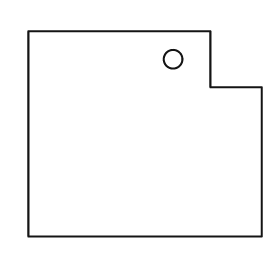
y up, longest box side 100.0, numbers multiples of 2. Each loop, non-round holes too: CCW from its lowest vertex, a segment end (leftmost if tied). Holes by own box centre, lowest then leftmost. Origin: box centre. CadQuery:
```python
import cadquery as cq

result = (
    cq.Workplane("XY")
    .moveTo(-50.0, -44.0)
    .lineTo(50.0, -44.0)
    .lineTo(50.0, 20.0)
    .lineTo(28.0, 20.0)
    .lineTo(28.0, 44.0)
    .lineTo(-50.0, 44.0)
    .close()
    .moveTo(12.0, 32.0)
    .circle(4.0)
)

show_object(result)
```